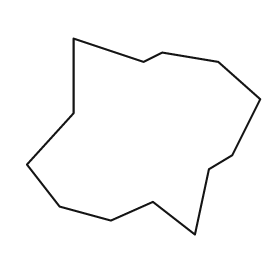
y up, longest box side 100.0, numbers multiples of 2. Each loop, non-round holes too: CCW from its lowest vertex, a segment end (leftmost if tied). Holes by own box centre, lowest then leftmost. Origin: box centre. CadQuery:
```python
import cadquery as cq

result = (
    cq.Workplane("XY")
    .moveTo(22.0, -42.0)
    .lineTo(28.0, -14.0)
    .lineTo(38.0, -8.0)
    .lineTo(50.0, 16.0)
    .lineTo(32.0, 32.0)
    .lineTo(8.0, 36.0)
    .lineTo(0.0, 32.0)
    .lineTo(-30.0, 42.0)
    .lineTo(-30.0, 10.0)
    .lineTo(-50.0, -12.0)
    .lineTo(-36.0, -30.0)
    .lineTo(-14.0, -36.0)
    .lineTo(4.0, -28.0)
    .close()
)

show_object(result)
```